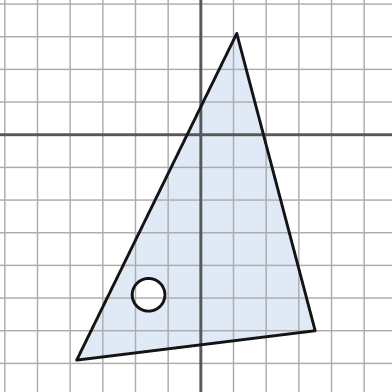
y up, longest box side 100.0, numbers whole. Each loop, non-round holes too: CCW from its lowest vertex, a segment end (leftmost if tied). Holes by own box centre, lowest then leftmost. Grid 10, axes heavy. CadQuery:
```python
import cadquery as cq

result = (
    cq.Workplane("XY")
    .moveTo(-38.0, -69.0)
    .lineTo(35.0, -60.0)
    .lineTo(11.0, 31.0)
    .close()
    .moveTo(-16.0, -49.0)
    .circle(5.0)
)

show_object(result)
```